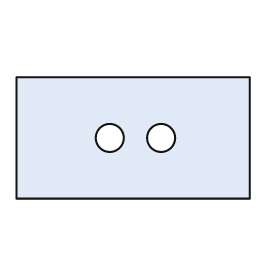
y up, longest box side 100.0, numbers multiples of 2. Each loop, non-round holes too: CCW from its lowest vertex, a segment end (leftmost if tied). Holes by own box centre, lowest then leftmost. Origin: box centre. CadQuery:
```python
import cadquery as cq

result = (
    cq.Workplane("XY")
    .moveTo(-50.0, -26.0)
    .lineTo(50.0, -26.0)
    .lineTo(50.0, 26.0)
    .lineTo(-50.0, 26.0)
    .close()
    .moveTo(-10.0, 0.0)
    .circle(6.0)
    .moveTo(12.0, 0.0)
    .circle(6.0)
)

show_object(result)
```